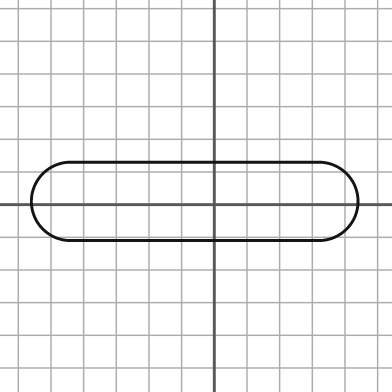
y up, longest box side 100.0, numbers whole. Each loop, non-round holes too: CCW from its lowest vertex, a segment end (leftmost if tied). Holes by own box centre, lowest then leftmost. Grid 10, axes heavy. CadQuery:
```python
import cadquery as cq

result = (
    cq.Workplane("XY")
    .moveTo(-44.0, -11.0)
    .lineTo(32.0, -11.0)
    .threePointArc((44.0, 1.0), (32.0, 13.0))
    .lineTo(-44.0, 13.0)
    .threePointArc((-56.0, 1.0), (-44.0, -11.0))
    .close()
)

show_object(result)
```